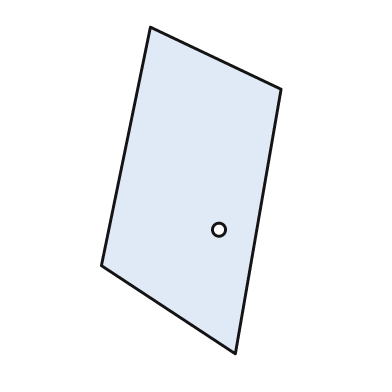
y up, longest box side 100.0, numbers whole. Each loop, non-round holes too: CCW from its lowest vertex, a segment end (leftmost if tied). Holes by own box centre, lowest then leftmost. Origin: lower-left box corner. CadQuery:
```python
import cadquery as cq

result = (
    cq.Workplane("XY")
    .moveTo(41.0, 0.0)
    .lineTo(55.0, 81.0)
    .lineTo(15.0, 100.0)
    .lineTo(0.0, 27.0)
    .close()
    .moveTo(36.0, 38.0)
    .circle(2.0)
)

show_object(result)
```